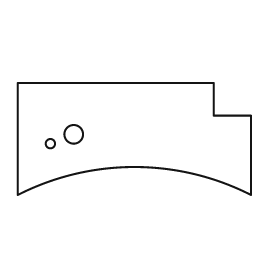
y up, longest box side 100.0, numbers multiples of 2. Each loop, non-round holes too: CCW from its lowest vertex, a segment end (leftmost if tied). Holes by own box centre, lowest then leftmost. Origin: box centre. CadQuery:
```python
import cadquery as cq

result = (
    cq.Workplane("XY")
    .moveTo(-50.0, -24.0)
    .threePointArc((0.0, -12.0), (50.0, -24.0))
    .lineTo(50.0, 10.0)
    .lineTo(34.0, 10.0)
    .lineTo(34.0, 24.0)
    .lineTo(-50.0, 24.0)
    .close()
    .moveTo(-36.0, -2.0)
    .circle(2.0)
    .moveTo(-26.0, 2.0)
    .circle(4.0)
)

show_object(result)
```